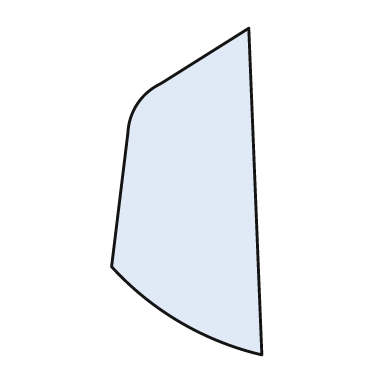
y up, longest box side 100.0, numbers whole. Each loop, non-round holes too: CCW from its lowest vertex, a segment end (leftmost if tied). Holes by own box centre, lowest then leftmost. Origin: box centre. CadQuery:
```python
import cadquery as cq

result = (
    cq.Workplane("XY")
    .moveTo(23.0, -50.0)
    .lineTo(19.0, 50.0)
    .lineTo(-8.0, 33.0)
    .threePointArc((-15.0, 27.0), (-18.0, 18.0))
    .lineTo(-23.0, -23.0)
    .threePointArc((-2.0, -40.0), (23.0, -50.0))
    .close()
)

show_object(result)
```